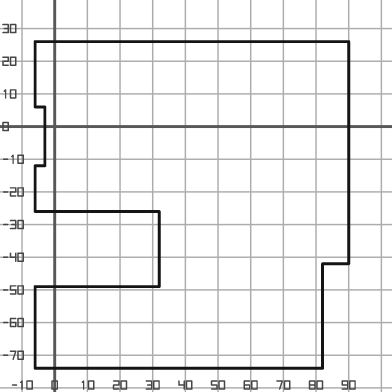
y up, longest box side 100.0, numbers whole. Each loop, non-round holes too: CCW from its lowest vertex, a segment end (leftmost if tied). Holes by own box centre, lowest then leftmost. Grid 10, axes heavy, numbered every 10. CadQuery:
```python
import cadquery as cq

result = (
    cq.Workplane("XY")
    .moveTo(-6.0, -74.0)
    .lineTo(82.0, -74.0)
    .lineTo(82.0, -42.0)
    .lineTo(90.0, -42.0)
    .lineTo(90.0, 26.0)
    .lineTo(-6.0, 26.0)
    .lineTo(-6.0, 6.0)
    .lineTo(-3.0, 6.0)
    .lineTo(-3.0, -12.0)
    .lineTo(-6.0, -12.0)
    .lineTo(-6.0, -26.0)
    .lineTo(32.0, -26.0)
    .lineTo(32.0, -49.0)
    .lineTo(-6.0, -49.0)
    .close()
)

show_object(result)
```